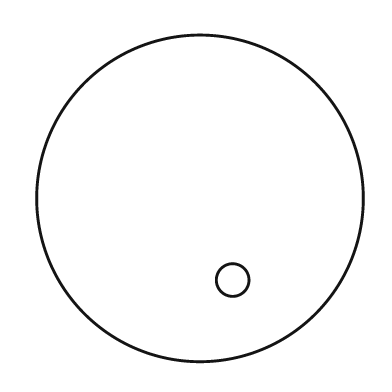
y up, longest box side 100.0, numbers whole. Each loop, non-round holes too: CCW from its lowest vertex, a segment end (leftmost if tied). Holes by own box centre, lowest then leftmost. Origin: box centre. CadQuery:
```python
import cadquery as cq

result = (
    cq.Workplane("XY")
    .moveTo(0.0, 0.0)
    .circle(50.0)
    .moveTo(10.0, -25.0)
    .circle(5.0)
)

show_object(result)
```